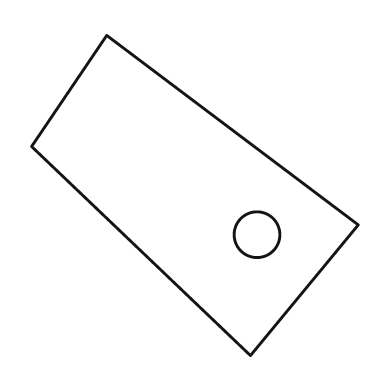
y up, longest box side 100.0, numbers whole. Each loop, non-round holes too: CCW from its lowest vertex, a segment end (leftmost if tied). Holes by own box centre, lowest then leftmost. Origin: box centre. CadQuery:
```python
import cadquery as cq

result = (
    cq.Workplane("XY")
    .moveTo(17.0, -49.0)
    .lineTo(50.0, -9.0)
    .lineTo(-27.0, 49.0)
    .lineTo(-50.0, 15.0)
    .close()
    .moveTo(19.0, -12.0)
    .circle(7.0)
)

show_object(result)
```